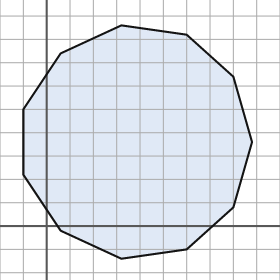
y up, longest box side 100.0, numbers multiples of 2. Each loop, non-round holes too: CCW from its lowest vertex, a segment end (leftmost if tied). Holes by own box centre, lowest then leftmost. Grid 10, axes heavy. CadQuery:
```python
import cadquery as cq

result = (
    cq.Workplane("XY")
    .moveTo(32.0, -14.0)
    .lineTo(60.0, -10.0)
    .lineTo(80.0, 8.0)
    .lineTo(88.0, 36.0)
    .lineTo(80.0, 64.0)
    .lineTo(60.0, 82.0)
    .lineTo(32.0, 86.0)
    .lineTo(6.0, 74.0)
    .lineTo(-10.0, 50.0)
    .lineTo(-10.0, 22.0)
    .lineTo(6.0, -2.0)
    .close()
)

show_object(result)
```